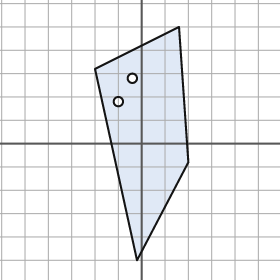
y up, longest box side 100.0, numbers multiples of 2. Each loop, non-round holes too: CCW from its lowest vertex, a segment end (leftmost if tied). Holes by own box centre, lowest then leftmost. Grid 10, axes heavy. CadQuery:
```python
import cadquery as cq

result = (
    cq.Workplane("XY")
    .moveTo(-2.0, -50.0)
    .lineTo(20.0, -8.0)
    .lineTo(16.0, 50.0)
    .lineTo(-20.0, 32.0)
    .close()
    .moveTo(-10.0, 18.0)
    .circle(2.0)
    .moveTo(-4.0, 28.0)
    .circle(2.0)
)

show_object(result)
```